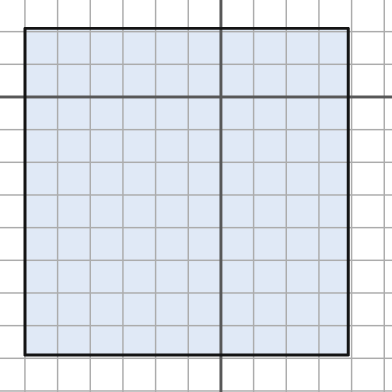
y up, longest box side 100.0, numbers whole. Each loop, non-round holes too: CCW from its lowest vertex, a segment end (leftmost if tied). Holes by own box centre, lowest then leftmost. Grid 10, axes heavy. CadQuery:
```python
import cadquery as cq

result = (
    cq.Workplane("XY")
    .moveTo(-60.0, -79.0)
    .lineTo(39.0, -79.0)
    .lineTo(39.0, 21.0)
    .lineTo(-60.0, 21.0)
    .close()
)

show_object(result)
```